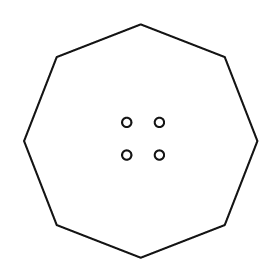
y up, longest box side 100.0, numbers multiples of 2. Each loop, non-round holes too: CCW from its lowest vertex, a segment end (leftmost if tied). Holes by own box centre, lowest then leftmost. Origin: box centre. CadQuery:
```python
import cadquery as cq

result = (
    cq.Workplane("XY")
    .moveTo(0.0, -50.0)
    .lineTo(36.0, -36.0)
    .lineTo(50.0, 0.0)
    .lineTo(36.0, 36.0)
    .lineTo(0.0, 50.0)
    .lineTo(-36.0, 36.0)
    .lineTo(-50.0, 0.0)
    .lineTo(-36.0, -36.0)
    .close()
    .moveTo(-6.0, -6.0)
    .circle(2.0)
    .moveTo(8.0, -6.0)
    .circle(2.0)
    .moveTo(-6.0, 8.0)
    .circle(2.0)
    .moveTo(8.0, 8.0)
    .circle(2.0)
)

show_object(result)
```